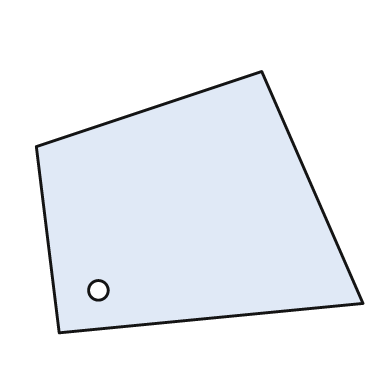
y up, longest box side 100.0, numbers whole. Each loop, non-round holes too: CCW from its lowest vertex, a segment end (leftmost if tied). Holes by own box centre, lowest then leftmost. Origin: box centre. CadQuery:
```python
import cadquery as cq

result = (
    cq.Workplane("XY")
    .moveTo(-43.0, -40.0)
    .lineTo(50.0, -31.0)
    .lineTo(19.0, 40.0)
    .lineTo(-50.0, 17.0)
    .close()
    .moveTo(-31.0, -27.0)
    .circle(3.0)
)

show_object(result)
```